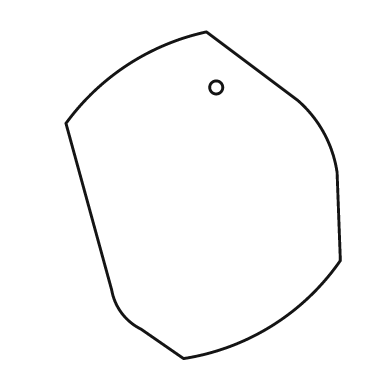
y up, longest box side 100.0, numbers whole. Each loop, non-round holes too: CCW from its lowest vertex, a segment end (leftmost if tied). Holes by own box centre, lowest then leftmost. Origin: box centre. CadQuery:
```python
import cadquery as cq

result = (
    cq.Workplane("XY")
    .moveTo(-6.0, -50.0)
    .threePointArc((21.0, -40.0), (42.0, -20.0))
    .lineTo(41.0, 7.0)
    .threePointArc((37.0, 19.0), (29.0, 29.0))
    .lineTo(1.0, 50.0)
    .threePointArc((-23.0, 40.0), (-42.0, 22.0))
    .lineTo(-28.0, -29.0)
    .threePointArc((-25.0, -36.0), (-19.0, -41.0))
    .close()
    .moveTo(4.0, 33.0)
    .circle(2.0)
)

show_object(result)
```